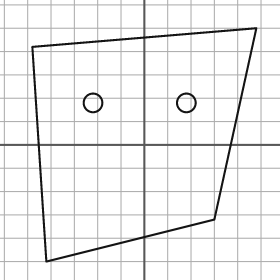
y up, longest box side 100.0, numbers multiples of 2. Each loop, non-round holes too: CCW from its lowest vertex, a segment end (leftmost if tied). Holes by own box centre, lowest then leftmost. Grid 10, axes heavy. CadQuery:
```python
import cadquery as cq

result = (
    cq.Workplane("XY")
    .moveTo(-42.0, -50.0)
    .lineTo(30.0, -32.0)
    .lineTo(48.0, 50.0)
    .lineTo(-48.0, 42.0)
    .close()
    .moveTo(-22.0, 18.0)
    .circle(4.0)
    .moveTo(18.0, 18.0)
    .circle(4.0)
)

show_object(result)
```